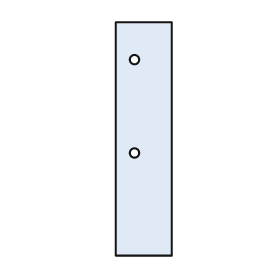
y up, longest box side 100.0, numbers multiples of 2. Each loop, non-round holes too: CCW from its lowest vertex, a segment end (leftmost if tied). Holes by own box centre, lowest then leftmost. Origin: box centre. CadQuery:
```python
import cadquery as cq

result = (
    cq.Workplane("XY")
    .moveTo(-12.0, -50.0)
    .lineTo(12.0, -50.0)
    .lineTo(12.0, 50.0)
    .lineTo(-12.0, 50.0)
    .close()
    .moveTo(-4.0, -6.0)
    .circle(2.0)
    .moveTo(-4.0, 34.0)
    .circle(2.0)
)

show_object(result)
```